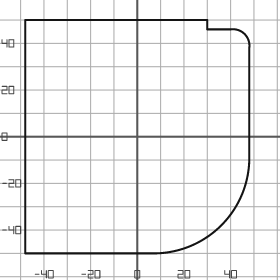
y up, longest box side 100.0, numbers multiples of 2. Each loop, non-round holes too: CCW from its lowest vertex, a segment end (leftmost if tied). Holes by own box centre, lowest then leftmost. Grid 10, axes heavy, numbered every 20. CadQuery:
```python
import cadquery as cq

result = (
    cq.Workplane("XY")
    .moveTo(-48.0, -50.0)
    .lineTo(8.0, -50.0)
    .threePointArc((36.0, -38.0), (48.0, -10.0))
    .lineTo(48.0, 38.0)
    .threePointArc((46.0, 44.0), (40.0, 46.0))
    .lineTo(30.0, 46.0)
    .lineTo(30.0, 50.0)
    .lineTo(-48.0, 50.0)
    .close()
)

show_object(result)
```